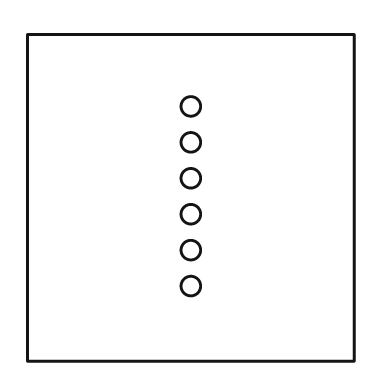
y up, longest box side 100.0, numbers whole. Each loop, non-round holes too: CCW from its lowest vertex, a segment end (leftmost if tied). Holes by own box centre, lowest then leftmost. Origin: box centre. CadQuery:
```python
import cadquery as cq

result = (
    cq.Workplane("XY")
    .moveTo(-50.0, -50.0)
    .lineTo(50.0, -50.0)
    .lineTo(50.0, 50.0)
    .lineTo(-50.0, 50.0)
    .close()
    .moveTo(0.0, -27.0)
    .circle(3.0)
    .moveTo(0.0, -16.0)
    .circle(3.0)
    .moveTo(0.0, -5.0)
    .circle(3.0)
    .moveTo(0.0, 6.0)
    .circle(3.0)
    .moveTo(0.0, 17.0)
    .circle(3.0)
    .moveTo(0.0, 28.0)
    .circle(3.0)
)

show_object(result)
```